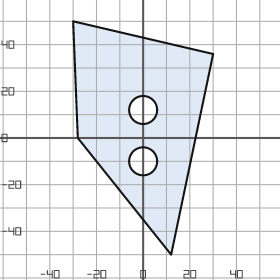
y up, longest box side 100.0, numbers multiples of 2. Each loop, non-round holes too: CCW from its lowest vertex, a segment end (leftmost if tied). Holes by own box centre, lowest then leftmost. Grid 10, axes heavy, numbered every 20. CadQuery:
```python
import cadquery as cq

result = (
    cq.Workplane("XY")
    .moveTo(12.0, -50.0)
    .lineTo(30.0, 36.0)
    .lineTo(-30.0, 50.0)
    .lineTo(-28.0, 0.0)
    .close()
    .moveTo(0.0, -10.0)
    .circle(6.0)
    .moveTo(0.0, 12.0)
    .circle(6.0)
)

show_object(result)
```